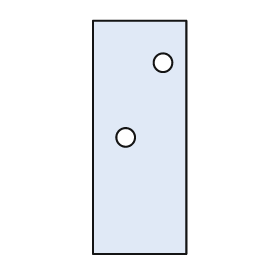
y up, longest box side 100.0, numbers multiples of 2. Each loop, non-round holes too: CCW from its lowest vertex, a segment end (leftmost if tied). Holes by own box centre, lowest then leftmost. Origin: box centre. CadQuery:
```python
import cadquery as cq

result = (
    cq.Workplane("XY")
    .moveTo(-20.0, -50.0)
    .lineTo(20.0, -50.0)
    .lineTo(20.0, 50.0)
    .lineTo(-20.0, 50.0)
    .close()
    .moveTo(-6.0, 0.0)
    .circle(4.0)
    .moveTo(10.0, 32.0)
    .circle(4.0)
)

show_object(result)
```